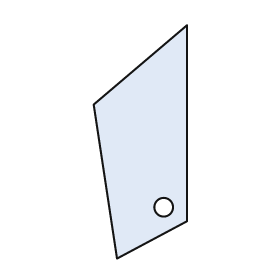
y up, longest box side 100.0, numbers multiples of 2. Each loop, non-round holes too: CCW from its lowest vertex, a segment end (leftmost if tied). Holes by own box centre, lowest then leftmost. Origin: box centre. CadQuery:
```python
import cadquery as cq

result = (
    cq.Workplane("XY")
    .moveTo(-10.0, -50.0)
    .lineTo(20.0, -34.0)
    .lineTo(20.0, 50.0)
    .lineTo(-20.0, 16.0)
    .close()
    .moveTo(10.0, -28.0)
    .circle(4.0)
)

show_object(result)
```